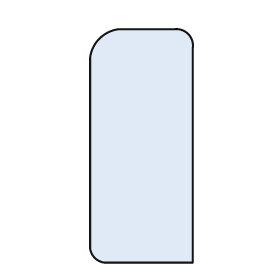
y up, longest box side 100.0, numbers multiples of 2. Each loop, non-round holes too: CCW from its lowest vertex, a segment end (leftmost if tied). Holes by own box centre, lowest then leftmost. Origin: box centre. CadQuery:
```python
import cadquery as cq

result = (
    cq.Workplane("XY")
    .moveTo(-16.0, -50.0)
    .lineTo(22.0, -50.0)
    .lineTo(22.0, 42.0)
    .threePointArc((20.0, 48.0), (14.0, 50.0))
    .lineTo(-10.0, 50.0)
    .threePointArc((-18.0, 46.0), (-22.0, 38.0))
    .lineTo(-22.0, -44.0)
    .threePointArc((-20.0, -48.0), (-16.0, -50.0))
    .close()
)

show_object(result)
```